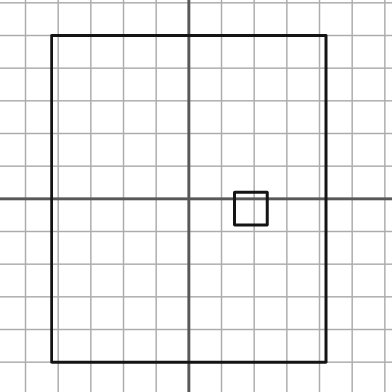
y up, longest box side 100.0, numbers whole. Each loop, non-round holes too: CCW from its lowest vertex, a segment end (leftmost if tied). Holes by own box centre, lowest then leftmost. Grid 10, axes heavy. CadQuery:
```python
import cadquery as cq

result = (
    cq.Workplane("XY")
    .moveTo(-42.0, -50.0)
    .lineTo(42.0, -50.0)
    .lineTo(42.0, 50.0)
    .lineTo(-42.0, 50.0)
    .close()
    .moveTo(14.0, -8.0)
    .lineTo(24.0, -8.0)
    .lineTo(24.0, 2.0)
    .lineTo(14.0, 2.0)
    .close()
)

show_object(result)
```